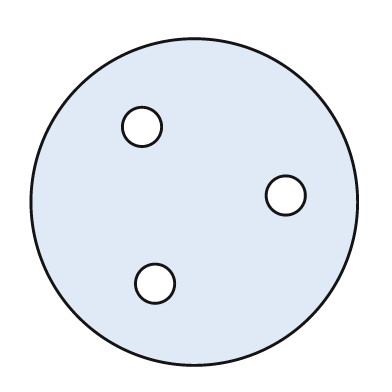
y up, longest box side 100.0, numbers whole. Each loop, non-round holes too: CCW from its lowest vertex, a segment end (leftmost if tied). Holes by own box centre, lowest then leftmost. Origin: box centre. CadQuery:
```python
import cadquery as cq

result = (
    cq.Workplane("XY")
    .moveTo(0.0, 0.0)
    .circle(50.0)
    .moveTo(-12.0, -25.0)
    .circle(6.0)
    .moveTo(28.0, 2.0)
    .circle(6.0)
    .moveTo(-16.0, 23.0)
    .circle(6.0)
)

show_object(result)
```